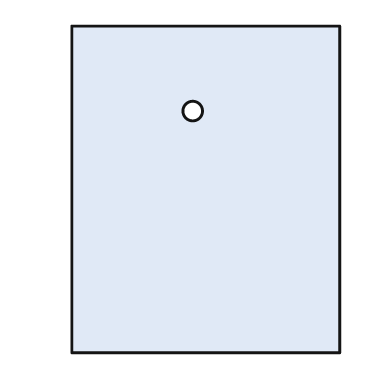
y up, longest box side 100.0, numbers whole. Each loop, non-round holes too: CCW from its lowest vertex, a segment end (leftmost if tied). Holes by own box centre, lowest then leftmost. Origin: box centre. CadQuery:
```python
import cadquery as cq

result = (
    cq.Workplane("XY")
    .moveTo(-41.0, -50.0)
    .lineTo(41.0, -50.0)
    .lineTo(41.0, 50.0)
    .lineTo(-41.0, 50.0)
    .close()
    .moveTo(-4.0, 24.0)
    .circle(3.0)
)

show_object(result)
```